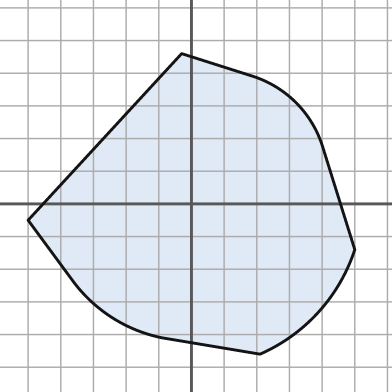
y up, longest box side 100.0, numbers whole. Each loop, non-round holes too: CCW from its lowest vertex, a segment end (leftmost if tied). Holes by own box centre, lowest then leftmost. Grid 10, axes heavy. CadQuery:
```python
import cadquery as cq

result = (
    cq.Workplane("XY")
    .moveTo(21.0, -46.0)
    .threePointArc((39.0, -33.0), (50.0, -14.0))
    .lineTo(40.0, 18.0)
    .threePointArc((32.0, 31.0), (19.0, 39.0))
    .lineTo(-3.0, 46.0)
    .lineTo(-50.0, -5.0)
    .lineTo(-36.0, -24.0)
    .threePointArc((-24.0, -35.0), (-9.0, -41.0))
    .close()
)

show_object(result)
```